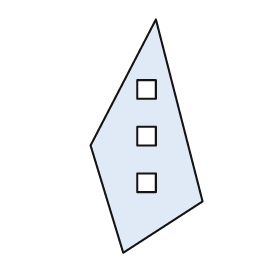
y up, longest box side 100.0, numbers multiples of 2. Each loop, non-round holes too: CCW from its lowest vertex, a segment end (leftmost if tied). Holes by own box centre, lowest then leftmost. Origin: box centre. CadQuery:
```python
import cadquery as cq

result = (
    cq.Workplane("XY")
    .moveTo(-10.0, -50.0)
    .lineTo(24.0, -28.0)
    .lineTo(4.0, 50.0)
    .lineTo(-24.0, -4.0)
    .close()
    .moveTo(-4.0, -24.0)
    .lineTo(4.0, -24.0)
    .lineTo(4.0, -16.0)
    .lineTo(-4.0, -16.0)
    .close()
    .moveTo(-4.0, -4.0)
    .lineTo(4.0, -4.0)
    .lineTo(4.0, 4.0)
    .lineTo(-4.0, 4.0)
    .close()
    .moveTo(-4.0, 16.0)
    .lineTo(4.0, 16.0)
    .lineTo(4.0, 24.0)
    .lineTo(-4.0, 24.0)
    .close()
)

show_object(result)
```